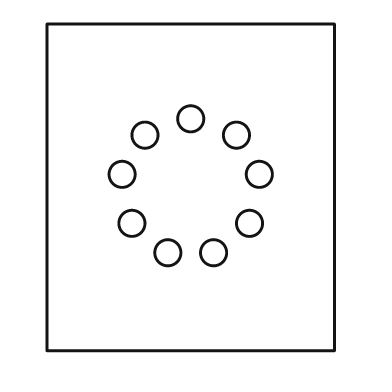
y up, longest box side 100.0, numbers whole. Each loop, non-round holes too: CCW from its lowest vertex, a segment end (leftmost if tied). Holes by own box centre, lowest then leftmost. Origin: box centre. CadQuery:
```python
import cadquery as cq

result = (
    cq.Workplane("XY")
    .moveTo(-44.0, -50.0)
    .lineTo(44.0, -50.0)
    .lineTo(44.0, 50.0)
    .lineTo(-44.0, 50.0)
    .close()
    .moveTo(-7.0, -20.0)
    .circle(4.0)
    .moveTo(7.0, -20.0)
    .circle(4.0)
    .moveTo(-18.0, -11.0)
    .circle(4.0)
    .moveTo(18.0, -11.0)
    .circle(4.0)
    .moveTo(-21.0, 4.0)
    .circle(4.0)
    .moveTo(21.0, 4.0)
    .circle(4.0)
    .moveTo(-14.0, 16.0)
    .circle(4.0)
    .moveTo(14.0, 16.0)
    .circle(4.0)
    .moveTo(0.0, 21.0)
    .circle(4.0)
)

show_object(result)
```